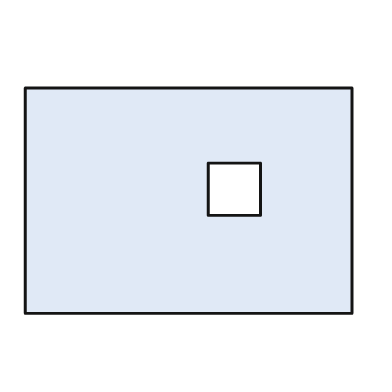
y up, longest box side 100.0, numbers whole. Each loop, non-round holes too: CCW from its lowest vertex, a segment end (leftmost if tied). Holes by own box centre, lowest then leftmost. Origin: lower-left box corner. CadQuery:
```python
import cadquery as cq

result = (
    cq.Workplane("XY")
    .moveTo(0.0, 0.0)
    .lineTo(100.0, 0.0)
    .lineTo(100.0, 69.0)
    .lineTo(0.0, 69.0)
    .close()
    .moveTo(56.0, 30.0)
    .lineTo(72.0, 30.0)
    .lineTo(72.0, 46.0)
    .lineTo(56.0, 46.0)
    .close()
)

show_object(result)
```